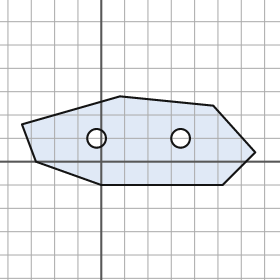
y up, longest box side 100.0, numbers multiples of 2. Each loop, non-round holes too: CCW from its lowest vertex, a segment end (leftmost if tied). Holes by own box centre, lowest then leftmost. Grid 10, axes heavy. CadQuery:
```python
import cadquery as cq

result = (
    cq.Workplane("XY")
    .moveTo(0.0, -10.0)
    .lineTo(52.0, -10.0)
    .lineTo(66.0, 4.0)
    .lineTo(48.0, 24.0)
    .lineTo(8.0, 28.0)
    .lineTo(-34.0, 16.0)
    .lineTo(-28.0, 0.0)
    .close()
    .moveTo(-2.0, 10.0)
    .circle(4.0)
    .moveTo(34.0, 10.0)
    .circle(4.0)
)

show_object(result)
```